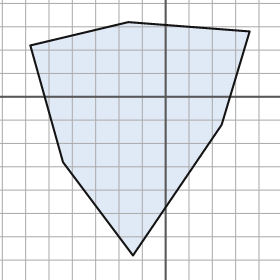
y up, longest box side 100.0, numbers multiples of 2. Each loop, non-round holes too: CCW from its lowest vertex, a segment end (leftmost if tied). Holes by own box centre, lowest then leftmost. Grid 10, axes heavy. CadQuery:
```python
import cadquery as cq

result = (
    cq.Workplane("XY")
    .moveTo(-14.0, -68.0)
    .lineTo(24.0, -12.0)
    .lineTo(36.0, 28.0)
    .lineTo(-16.0, 32.0)
    .lineTo(-58.0, 22.0)
    .lineTo(-44.0, -28.0)
    .close()
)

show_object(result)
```